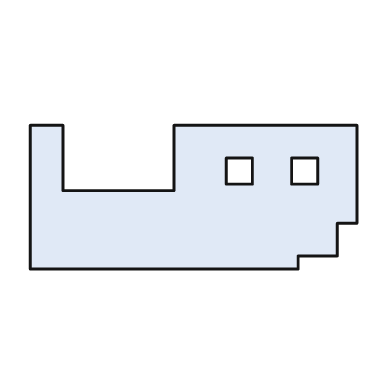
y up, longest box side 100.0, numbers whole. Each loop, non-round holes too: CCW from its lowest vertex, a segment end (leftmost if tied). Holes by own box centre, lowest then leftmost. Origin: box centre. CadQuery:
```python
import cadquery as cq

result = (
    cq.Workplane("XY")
    .moveTo(-50.0, -22.0)
    .lineTo(32.0, -22.0)
    .lineTo(32.0, -18.0)
    .lineTo(44.0, -18.0)
    .lineTo(44.0, -8.0)
    .lineTo(50.0, -8.0)
    .lineTo(50.0, 22.0)
    .lineTo(-6.0, 22.0)
    .lineTo(-6.0, 2.0)
    .lineTo(-40.0, 2.0)
    .lineTo(-40.0, 22.0)
    .lineTo(-50.0, 22.0)
    .close()
    .moveTo(10.0, 4.0)
    .lineTo(18.0, 4.0)
    .lineTo(18.0, 12.0)
    .lineTo(10.0, 12.0)
    .close()
    .moveTo(30.0, 4.0)
    .lineTo(38.0, 4.0)
    .lineTo(38.0, 12.0)
    .lineTo(30.0, 12.0)
    .close()
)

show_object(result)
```